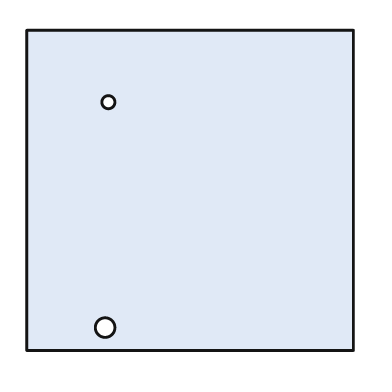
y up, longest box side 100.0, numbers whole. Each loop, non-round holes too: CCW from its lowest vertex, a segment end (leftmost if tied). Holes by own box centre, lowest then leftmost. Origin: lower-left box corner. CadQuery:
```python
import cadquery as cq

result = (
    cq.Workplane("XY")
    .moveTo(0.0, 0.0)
    .lineTo(100.0, 0.0)
    .lineTo(100.0, 98.0)
    .lineTo(0.0, 98.0)
    .close()
    .moveTo(24.0, 7.0)
    .circle(3.0)
    .moveTo(25.0, 76.0)
    .circle(2.0)
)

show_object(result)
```